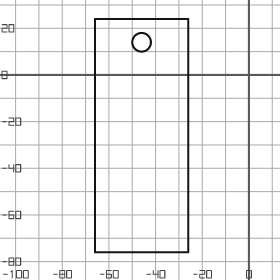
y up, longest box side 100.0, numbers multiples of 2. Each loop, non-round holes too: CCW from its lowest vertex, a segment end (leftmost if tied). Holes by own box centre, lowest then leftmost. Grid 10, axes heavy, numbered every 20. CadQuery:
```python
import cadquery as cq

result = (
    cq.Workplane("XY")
    .moveTo(-66.0, -76.0)
    .lineTo(-26.0, -76.0)
    .lineTo(-26.0, 24.0)
    .lineTo(-66.0, 24.0)
    .close()
    .moveTo(-46.0, 14.0)
    .circle(4.0)
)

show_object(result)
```